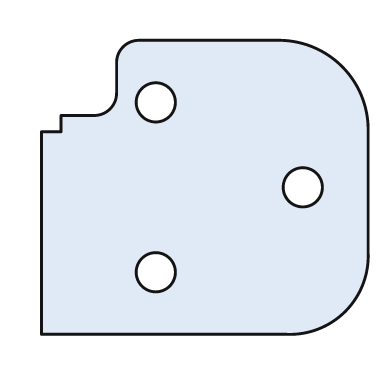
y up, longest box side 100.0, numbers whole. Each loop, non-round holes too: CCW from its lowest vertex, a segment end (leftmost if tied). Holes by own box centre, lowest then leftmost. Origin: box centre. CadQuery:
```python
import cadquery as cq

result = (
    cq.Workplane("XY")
    .moveTo(-50.0, -45.0)
    .lineTo(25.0, -45.0)
    .threePointArc((43.0, -38.0), (50.0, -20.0))
    .lineTo(50.0, 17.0)
    .threePointArc((42.0, 37.0), (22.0, 45.0))
    .lineTo(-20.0, 45.0)
    .threePointArc((-25.0, 43.0), (-27.0, 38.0))
    .lineTo(-27.0, 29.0)
    .threePointArc((-29.0, 24.0), (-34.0, 22.0))
    .lineTo(-44.0, 22.0)
    .lineTo(-44.0, 17.0)
    .lineTo(-50.0, 17.0)
    .close()
    .moveTo(-15.0, -26.0)
    .circle(6.0)
    .moveTo(30.0, 0.0)
    .circle(6.0)
    .moveTo(-15.0, 26.0)
    .circle(6.0)
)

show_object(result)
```